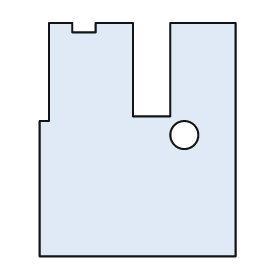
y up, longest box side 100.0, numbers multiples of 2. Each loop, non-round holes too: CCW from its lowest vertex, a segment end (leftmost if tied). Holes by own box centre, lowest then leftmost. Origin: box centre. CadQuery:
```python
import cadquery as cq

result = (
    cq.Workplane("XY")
    .moveTo(-42.0, -50.0)
    .lineTo(42.0, -50.0)
    .lineTo(42.0, 50.0)
    .lineTo(14.0, 50.0)
    .lineTo(14.0, 10.0)
    .lineTo(-2.0, 10.0)
    .lineTo(-2.0, 50.0)
    .lineTo(-18.0, 50.0)
    .lineTo(-18.0, 46.0)
    .lineTo(-28.0, 46.0)
    .lineTo(-28.0, 50.0)
    .lineTo(-38.0, 50.0)
    .lineTo(-38.0, 8.0)
    .lineTo(-42.0, 8.0)
    .close()
    .moveTo(20.0, 2.0)
    .circle(6.0)
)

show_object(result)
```